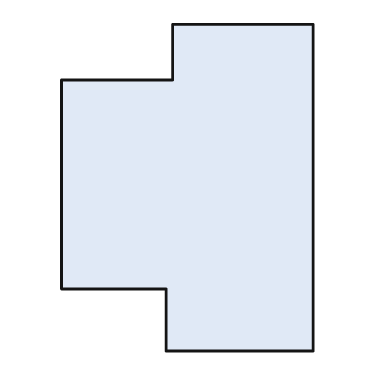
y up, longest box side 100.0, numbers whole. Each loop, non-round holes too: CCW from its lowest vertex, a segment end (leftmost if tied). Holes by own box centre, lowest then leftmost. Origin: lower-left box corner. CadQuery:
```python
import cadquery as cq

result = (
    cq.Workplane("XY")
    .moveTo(32.0, 0.0)
    .lineTo(77.0, 0.0)
    .lineTo(77.0, 100.0)
    .lineTo(34.0, 100.0)
    .lineTo(34.0, 83.0)
    .lineTo(0.0, 83.0)
    .lineTo(0.0, 19.0)
    .lineTo(32.0, 19.0)
    .close()
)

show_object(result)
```